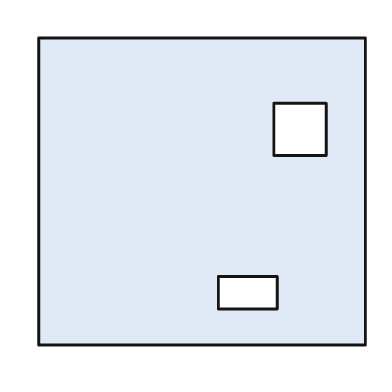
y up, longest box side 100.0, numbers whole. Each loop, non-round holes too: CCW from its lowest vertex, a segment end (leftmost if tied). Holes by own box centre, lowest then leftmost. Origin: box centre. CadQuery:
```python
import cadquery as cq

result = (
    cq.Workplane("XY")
    .moveTo(-50.0, -47.0)
    .lineTo(50.0, -47.0)
    .lineTo(50.0, 47.0)
    .lineTo(-50.0, 47.0)
    .close()
    .moveTo(5.0, -36.0)
    .lineTo(23.0, -36.0)
    .lineTo(23.0, -26.0)
    .lineTo(5.0, -26.0)
    .close()
    .moveTo(22.0, 11.0)
    .lineTo(38.0, 11.0)
    .lineTo(38.0, 27.0)
    .lineTo(22.0, 27.0)
    .close()
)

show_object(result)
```